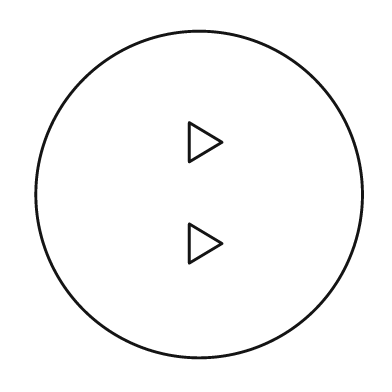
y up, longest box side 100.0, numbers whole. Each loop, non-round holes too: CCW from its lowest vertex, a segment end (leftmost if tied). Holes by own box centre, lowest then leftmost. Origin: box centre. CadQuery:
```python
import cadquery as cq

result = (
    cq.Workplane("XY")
    .moveTo(0.0, 0.0)
    .circle(50.0)
    .moveTo(-3.0, -21.0)
    .lineTo(7.0, -15.0)
    .lineTo(-3.0, -9.0)
    .close()
    .moveTo(-3.0, 10.0)
    .lineTo(7.0, 16.0)
    .lineTo(-3.0, 22.0)
    .close()
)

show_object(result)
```